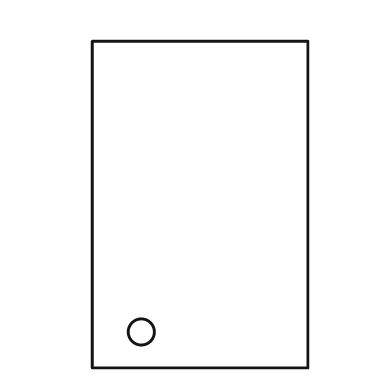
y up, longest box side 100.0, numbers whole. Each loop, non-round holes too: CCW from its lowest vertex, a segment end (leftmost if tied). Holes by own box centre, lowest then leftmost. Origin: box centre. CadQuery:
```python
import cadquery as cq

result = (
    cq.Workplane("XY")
    .moveTo(-33.0, -50.0)
    .lineTo(33.0, -50.0)
    .lineTo(33.0, 50.0)
    .lineTo(-33.0, 50.0)
    .close()
    .moveTo(-18.0, -39.0)
    .circle(4.0)
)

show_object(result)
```